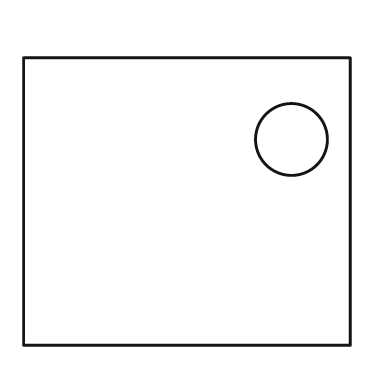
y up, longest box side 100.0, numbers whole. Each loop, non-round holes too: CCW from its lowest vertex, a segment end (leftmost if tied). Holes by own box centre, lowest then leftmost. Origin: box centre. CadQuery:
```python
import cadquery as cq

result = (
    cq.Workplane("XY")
    .moveTo(-50.0, -44.0)
    .lineTo(50.0, -44.0)
    .lineTo(50.0, 44.0)
    .lineTo(-50.0, 44.0)
    .close()
    .moveTo(32.0, 19.0)
    .circle(11.0)
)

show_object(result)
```